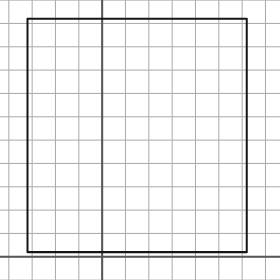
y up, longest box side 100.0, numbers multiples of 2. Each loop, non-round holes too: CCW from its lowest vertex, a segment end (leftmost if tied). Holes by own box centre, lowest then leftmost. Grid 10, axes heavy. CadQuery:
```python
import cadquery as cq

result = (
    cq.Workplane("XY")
    .moveTo(-32.0, 2.0)
    .lineTo(62.0, 2.0)
    .lineTo(62.0, 102.0)
    .lineTo(-32.0, 102.0)
    .close()
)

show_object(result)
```